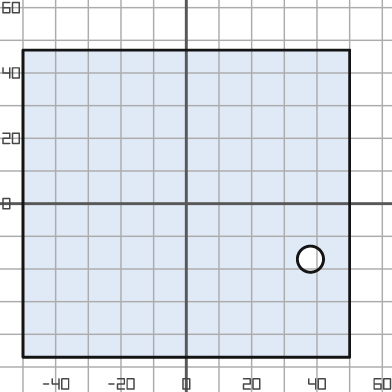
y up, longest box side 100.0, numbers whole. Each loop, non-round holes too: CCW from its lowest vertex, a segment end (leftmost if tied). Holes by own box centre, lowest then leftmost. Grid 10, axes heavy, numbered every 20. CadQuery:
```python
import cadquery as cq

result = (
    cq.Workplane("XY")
    .moveTo(-50.0, -47.0)
    .lineTo(50.0, -47.0)
    .lineTo(50.0, 47.0)
    .lineTo(-50.0, 47.0)
    .close()
    .moveTo(38.0, -17.0)
    .circle(4.0)
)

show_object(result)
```